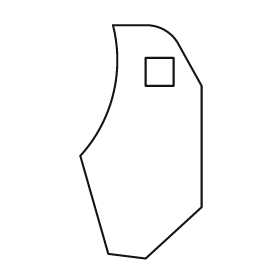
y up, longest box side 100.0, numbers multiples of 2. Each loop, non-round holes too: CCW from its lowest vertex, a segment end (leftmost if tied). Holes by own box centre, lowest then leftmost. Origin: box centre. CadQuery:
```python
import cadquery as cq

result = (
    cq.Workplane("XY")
    .moveTo(2.0, -50.0)
    .lineTo(26.0, -28.0)
    .lineTo(26.0, 24.0)
    .lineTo(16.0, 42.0)
    .threePointArc((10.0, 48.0), (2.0, 50.0))
    .lineTo(-12.0, 50.0)
    .threePointArc((-12.0, 20.0), (-26.0, -6.0))
    .lineTo(-14.0, -48.0)
    .close()
    .moveTo(2.0, 24.0)
    .lineTo(14.0, 24.0)
    .lineTo(14.0, 36.0)
    .lineTo(2.0, 36.0)
    .close()
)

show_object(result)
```